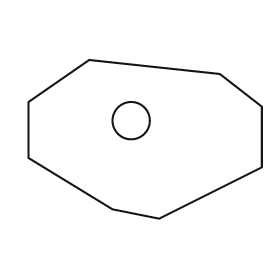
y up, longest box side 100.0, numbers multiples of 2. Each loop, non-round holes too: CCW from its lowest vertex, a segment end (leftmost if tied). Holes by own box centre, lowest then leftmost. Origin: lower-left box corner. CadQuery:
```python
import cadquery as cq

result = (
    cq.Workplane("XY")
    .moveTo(56.0, 0.0)
    .lineTo(100.0, 22.0)
    .lineTo(100.0, 48.0)
    .lineTo(82.0, 62.0)
    .lineTo(26.0, 68.0)
    .lineTo(0.0, 50.0)
    .lineTo(0.0, 26.0)
    .lineTo(36.0, 4.0)
    .close()
    .moveTo(44.0, 42.0)
    .circle(8.0)
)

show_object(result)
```